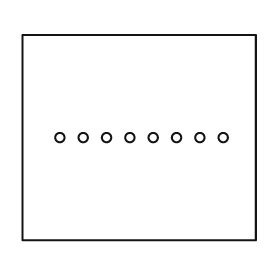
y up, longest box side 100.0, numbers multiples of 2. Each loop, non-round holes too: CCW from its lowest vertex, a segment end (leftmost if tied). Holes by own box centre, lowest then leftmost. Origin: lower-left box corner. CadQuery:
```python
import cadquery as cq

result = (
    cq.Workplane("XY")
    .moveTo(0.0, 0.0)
    .lineTo(100.0, 0.0)
    .lineTo(100.0, 88.0)
    .lineTo(0.0, 88.0)
    .close()
    .moveTo(16.0, 44.0)
    .circle(2.0)
    .moveTo(26.0, 44.0)
    .circle(2.0)
    .moveTo(36.0, 44.0)
    .circle(2.0)
    .moveTo(46.0, 44.0)
    .circle(2.0)
    .moveTo(56.0, 44.0)
    .circle(2.0)
    .moveTo(66.0, 44.0)
    .circle(2.0)
    .moveTo(76.0, 44.0)
    .circle(2.0)
    .moveTo(86.0, 44.0)
    .circle(2.0)
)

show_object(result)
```